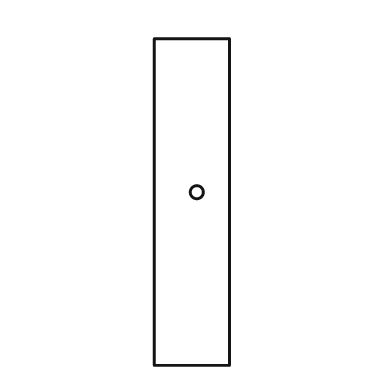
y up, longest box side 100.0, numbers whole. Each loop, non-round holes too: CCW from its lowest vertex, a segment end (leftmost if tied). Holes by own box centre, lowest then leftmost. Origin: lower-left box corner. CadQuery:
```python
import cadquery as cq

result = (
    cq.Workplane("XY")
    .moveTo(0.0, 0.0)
    .lineTo(23.0, 0.0)
    .lineTo(23.0, 100.0)
    .lineTo(0.0, 100.0)
    .close()
    .moveTo(13.0, 53.0)
    .circle(2.0)
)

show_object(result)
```